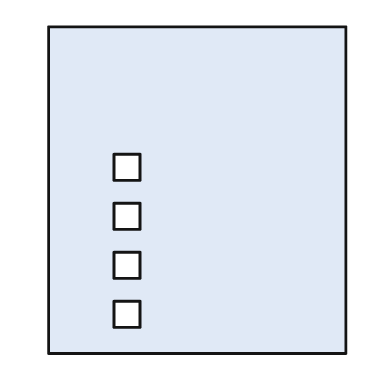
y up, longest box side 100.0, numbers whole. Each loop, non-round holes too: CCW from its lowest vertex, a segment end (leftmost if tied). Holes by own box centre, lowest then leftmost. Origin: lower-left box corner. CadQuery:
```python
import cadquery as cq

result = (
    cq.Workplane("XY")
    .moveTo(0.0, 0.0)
    .lineTo(91.0, 0.0)
    .lineTo(91.0, 100.0)
    .lineTo(0.0, 100.0)
    .close()
    .moveTo(20.0, 8.0)
    .lineTo(28.0, 8.0)
    .lineTo(28.0, 16.0)
    .lineTo(20.0, 16.0)
    .close()
    .moveTo(20.0, 23.0)
    .lineTo(28.0, 23.0)
    .lineTo(28.0, 31.0)
    .lineTo(20.0, 31.0)
    .close()
    .moveTo(20.0, 38.0)
    .lineTo(28.0, 38.0)
    .lineTo(28.0, 46.0)
    .lineTo(20.0, 46.0)
    .close()
    .moveTo(20.0, 53.0)
    .lineTo(28.0, 53.0)
    .lineTo(28.0, 61.0)
    .lineTo(20.0, 61.0)
    .close()
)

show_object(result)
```